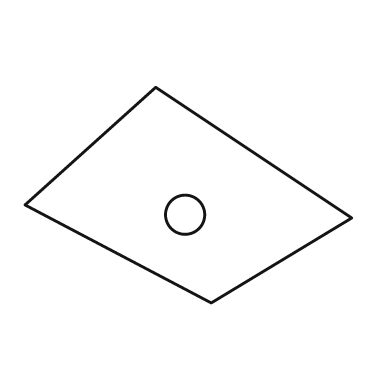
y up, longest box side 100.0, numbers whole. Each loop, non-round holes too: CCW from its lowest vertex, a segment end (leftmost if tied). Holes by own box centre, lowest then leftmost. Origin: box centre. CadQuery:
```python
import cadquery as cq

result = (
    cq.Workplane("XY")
    .moveTo(7.0, -33.0)
    .lineTo(50.0, -7.0)
    .lineTo(-10.0, 33.0)
    .lineTo(-50.0, -3.0)
    .close()
    .moveTo(-1.0, -6.0)
    .circle(6.0)
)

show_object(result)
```